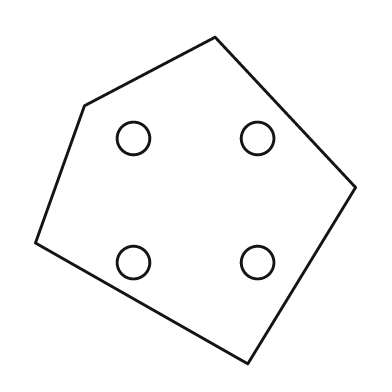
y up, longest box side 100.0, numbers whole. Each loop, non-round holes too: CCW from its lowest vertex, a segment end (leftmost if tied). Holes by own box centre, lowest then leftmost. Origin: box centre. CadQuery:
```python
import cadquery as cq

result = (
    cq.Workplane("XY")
    .moveTo(16.0, -50.0)
    .lineTo(49.0, 4.0)
    .lineTo(6.0, 50.0)
    .lineTo(-34.0, 29.0)
    .lineTo(-49.0, -13.0)
    .close()
    .moveTo(-19.0, -19.0)
    .circle(5.0)
    .moveTo(19.0, -19.0)
    .circle(5.0)
    .moveTo(-19.0, 19.0)
    .circle(5.0)
    .moveTo(19.0, 19.0)
    .circle(5.0)
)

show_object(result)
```